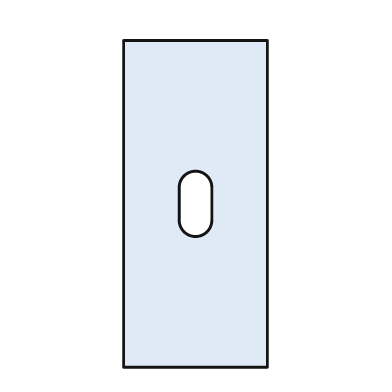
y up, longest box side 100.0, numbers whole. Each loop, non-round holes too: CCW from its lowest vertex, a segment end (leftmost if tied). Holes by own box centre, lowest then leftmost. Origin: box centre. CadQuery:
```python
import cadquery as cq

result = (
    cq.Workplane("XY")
    .moveTo(-22.0, -50.0)
    .lineTo(22.0, -50.0)
    .lineTo(22.0, 50.0)
    .lineTo(-22.0, 50.0)
    .close()
    .moveTo(-5.0, -5.0)
    .threePointArc((0.0, -10.0), (5.0, -5.0))
    .lineTo(5.0, 5.0)
    .threePointArc((0.0, 10.0), (-5.0, 5.0))
    .close()
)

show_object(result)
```